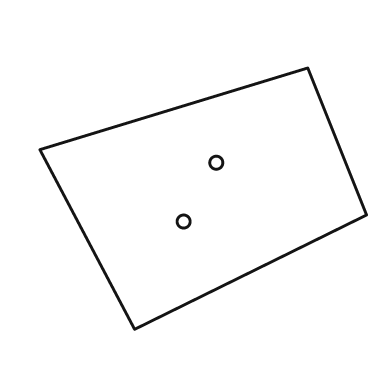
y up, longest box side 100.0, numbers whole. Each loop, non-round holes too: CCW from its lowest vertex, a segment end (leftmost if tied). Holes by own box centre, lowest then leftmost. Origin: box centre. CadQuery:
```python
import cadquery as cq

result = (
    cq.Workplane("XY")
    .moveTo(-21.0, -40.0)
    .lineTo(50.0, -5.0)
    .lineTo(32.0, 40.0)
    .lineTo(-50.0, 15.0)
    .close()
    .moveTo(-6.0, -7.0)
    .circle(2.0)
    .moveTo(4.0, 11.0)
    .circle(2.0)
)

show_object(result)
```